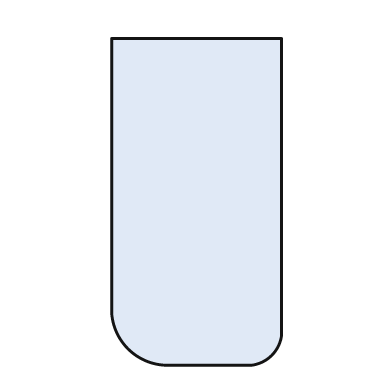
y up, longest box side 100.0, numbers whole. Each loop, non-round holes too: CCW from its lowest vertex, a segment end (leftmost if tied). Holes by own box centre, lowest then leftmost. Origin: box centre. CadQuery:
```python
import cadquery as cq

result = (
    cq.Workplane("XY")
    .moveTo(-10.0, -50.0)
    .lineTo(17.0, -50.0)
    .threePointArc((23.0, -47.0), (26.0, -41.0))
    .lineTo(26.0, 50.0)
    .lineTo(-26.0, 50.0)
    .lineTo(-26.0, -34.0)
    .threePointArc((-21.0, -45.0), (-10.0, -50.0))
    .close()
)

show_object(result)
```